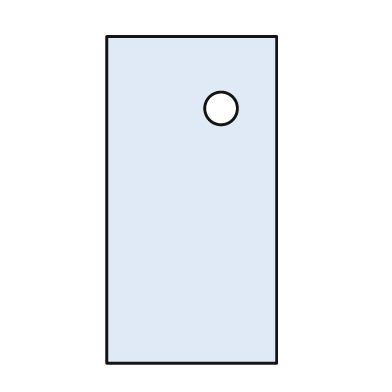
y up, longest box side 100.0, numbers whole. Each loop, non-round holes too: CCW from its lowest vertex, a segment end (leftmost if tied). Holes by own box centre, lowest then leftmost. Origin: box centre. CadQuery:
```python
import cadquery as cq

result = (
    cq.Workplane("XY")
    .moveTo(-26.0, -50.0)
    .lineTo(26.0, -50.0)
    .lineTo(26.0, 50.0)
    .lineTo(-26.0, 50.0)
    .close()
    .moveTo(9.0, 28.0)
    .circle(5.0)
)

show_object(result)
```